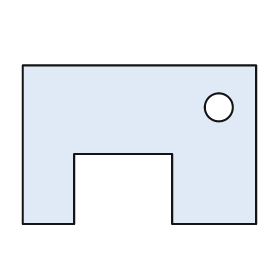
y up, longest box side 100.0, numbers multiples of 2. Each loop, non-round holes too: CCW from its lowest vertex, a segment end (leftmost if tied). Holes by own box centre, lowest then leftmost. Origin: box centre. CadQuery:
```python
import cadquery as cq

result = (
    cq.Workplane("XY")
    .moveTo(-50.0, -34.0)
    .lineTo(-28.0, -34.0)
    .lineTo(-28.0, -4.0)
    .lineTo(14.0, -4.0)
    .lineTo(14.0, -34.0)
    .lineTo(50.0, -34.0)
    .lineTo(50.0, 34.0)
    .lineTo(-50.0, 34.0)
    .close()
    .moveTo(34.0, 16.0)
    .circle(6.0)
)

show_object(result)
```